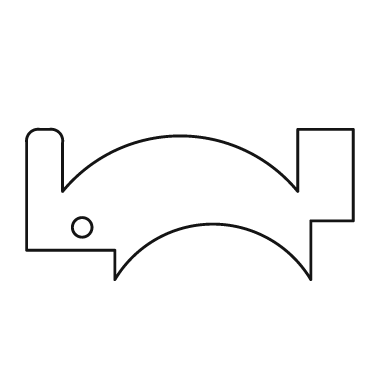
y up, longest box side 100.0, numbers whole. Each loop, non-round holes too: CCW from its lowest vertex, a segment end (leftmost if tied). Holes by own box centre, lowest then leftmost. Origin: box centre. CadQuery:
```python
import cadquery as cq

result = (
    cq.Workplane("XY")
    .moveTo(-23.0, -23.0)
    .threePointArc((7.0, -6.0), (37.0, -23.0))
    .lineTo(37.0, -5.0)
    .lineTo(50.0, -5.0)
    .lineTo(50.0, 23.0)
    .lineTo(33.0, 23.0)
    .lineTo(33.0, 4.0)
    .threePointArc((-3.0, 21.0), (-39.0, 4.0))
    .lineTo(-39.0, 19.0)
    .threePointArc((-40.0, 22.0), (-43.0, 23.0))
    .lineTo(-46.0, 23.0)
    .threePointArc((-49.0, 22.0), (-50.0, 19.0))
    .lineTo(-50.0, -14.0)
    .lineTo(-23.0, -14.0)
    .close()
    .moveTo(-33.0, -7.0)
    .circle(3.0)
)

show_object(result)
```